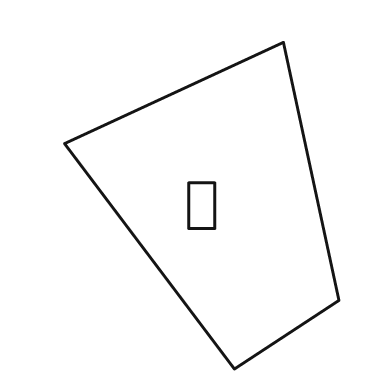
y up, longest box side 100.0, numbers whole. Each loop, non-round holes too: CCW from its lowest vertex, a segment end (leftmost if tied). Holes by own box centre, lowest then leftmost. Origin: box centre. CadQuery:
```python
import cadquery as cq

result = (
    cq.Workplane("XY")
    .moveTo(10.0, -50.0)
    .lineTo(42.0, -29.0)
    .lineTo(25.0, 50.0)
    .lineTo(-42.0, 19.0)
    .close()
    .moveTo(-4.0, -7.0)
    .lineTo(4.0, -7.0)
    .lineTo(4.0, 7.0)
    .lineTo(-4.0, 7.0)
    .close()
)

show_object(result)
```